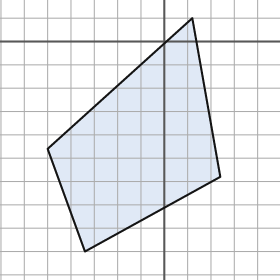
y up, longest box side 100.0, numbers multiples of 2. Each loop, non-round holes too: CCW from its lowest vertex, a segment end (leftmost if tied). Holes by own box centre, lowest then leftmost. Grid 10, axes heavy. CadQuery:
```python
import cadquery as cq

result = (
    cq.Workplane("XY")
    .moveTo(-34.0, -90.0)
    .lineTo(24.0, -58.0)
    .lineTo(12.0, 10.0)
    .lineTo(-50.0, -46.0)
    .close()
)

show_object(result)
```